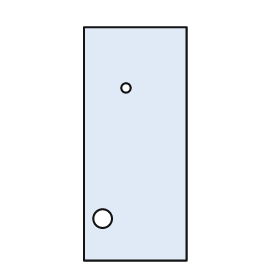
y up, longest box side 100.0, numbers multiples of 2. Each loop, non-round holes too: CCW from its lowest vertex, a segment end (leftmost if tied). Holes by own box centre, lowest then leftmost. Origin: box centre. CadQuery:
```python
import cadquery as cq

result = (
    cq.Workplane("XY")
    .moveTo(-22.0, -50.0)
    .lineTo(22.0, -50.0)
    .lineTo(22.0, 50.0)
    .lineTo(-22.0, 50.0)
    .close()
    .moveTo(-14.0, -32.0)
    .circle(4.0)
    .moveTo(-4.0, 24.0)
    .circle(2.0)
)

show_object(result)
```